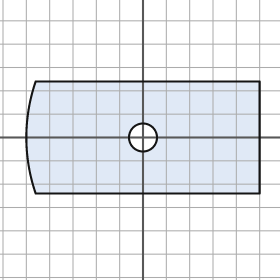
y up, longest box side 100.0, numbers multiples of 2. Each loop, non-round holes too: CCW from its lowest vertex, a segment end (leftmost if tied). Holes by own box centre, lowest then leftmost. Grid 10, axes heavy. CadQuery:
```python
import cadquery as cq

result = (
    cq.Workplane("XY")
    .moveTo(-46.0, -24.0)
    .lineTo(50.0, -24.0)
    .lineTo(50.0, 24.0)
    .lineTo(-46.0, 24.0)
    .threePointArc((-50.0, 0.0), (-46.0, -24.0))
    .close()
    .moveTo(0.0, 0.0)
    .circle(6.0)
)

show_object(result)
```